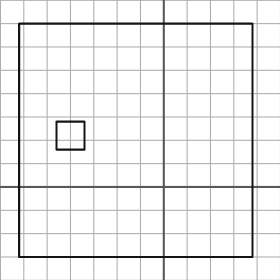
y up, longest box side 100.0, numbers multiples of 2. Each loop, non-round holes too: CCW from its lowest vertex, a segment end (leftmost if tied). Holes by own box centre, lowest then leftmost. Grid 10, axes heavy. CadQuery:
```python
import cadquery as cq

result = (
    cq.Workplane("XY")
    .moveTo(-62.0, -30.0)
    .lineTo(38.0, -30.0)
    .lineTo(38.0, 70.0)
    .lineTo(-62.0, 70.0)
    .close()
    .moveTo(-46.0, 16.0)
    .lineTo(-34.0, 16.0)
    .lineTo(-34.0, 28.0)
    .lineTo(-46.0, 28.0)
    .close()
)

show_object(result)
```